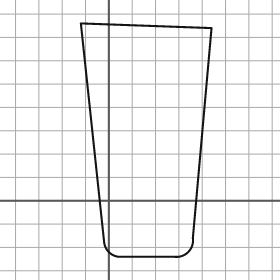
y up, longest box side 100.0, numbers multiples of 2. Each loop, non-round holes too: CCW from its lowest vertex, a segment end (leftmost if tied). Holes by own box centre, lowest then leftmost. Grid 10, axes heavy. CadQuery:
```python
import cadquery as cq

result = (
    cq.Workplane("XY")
    .moveTo(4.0, -24.0)
    .lineTo(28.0, -24.0)
    .threePointArc((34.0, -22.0), (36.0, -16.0))
    .lineTo(44.0, 74.0)
    .lineTo(-12.0, 76.0)
    .lineTo(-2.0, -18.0)
    .threePointArc((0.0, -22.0), (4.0, -24.0))
    .close()
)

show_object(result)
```